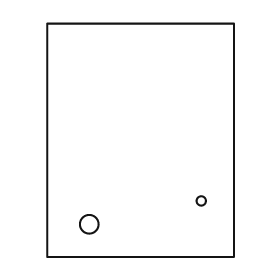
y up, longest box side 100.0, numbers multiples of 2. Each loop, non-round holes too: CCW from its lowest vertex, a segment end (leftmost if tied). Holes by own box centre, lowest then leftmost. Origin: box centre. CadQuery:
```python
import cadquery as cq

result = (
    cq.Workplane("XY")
    .moveTo(-40.0, -50.0)
    .lineTo(40.0, -50.0)
    .lineTo(40.0, 50.0)
    .lineTo(-40.0, 50.0)
    .close()
    .moveTo(-22.0, -36.0)
    .circle(4.0)
    .moveTo(26.0, -26.0)
    .circle(2.0)
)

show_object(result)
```